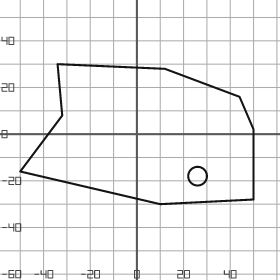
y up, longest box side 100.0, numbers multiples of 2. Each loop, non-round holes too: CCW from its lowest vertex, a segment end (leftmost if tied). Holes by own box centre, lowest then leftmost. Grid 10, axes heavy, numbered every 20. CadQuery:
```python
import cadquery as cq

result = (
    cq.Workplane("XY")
    .moveTo(10.0, -30.0)
    .lineTo(50.0, -28.0)
    .lineTo(50.0, 2.0)
    .lineTo(44.0, 16.0)
    .lineTo(12.0, 28.0)
    .lineTo(-34.0, 30.0)
    .lineTo(-32.0, 8.0)
    .lineTo(-50.0, -16.0)
    .close()
    .moveTo(26.0, -18.0)
    .circle(4.0)
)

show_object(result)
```